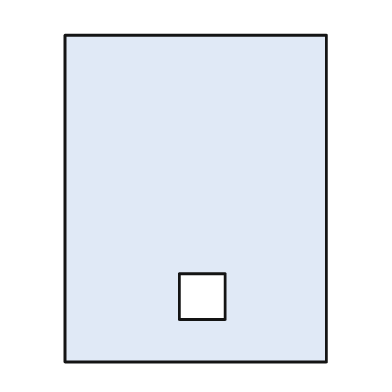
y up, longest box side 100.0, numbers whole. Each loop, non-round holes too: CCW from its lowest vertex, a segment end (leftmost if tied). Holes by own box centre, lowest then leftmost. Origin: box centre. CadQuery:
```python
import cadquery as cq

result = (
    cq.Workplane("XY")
    .moveTo(-40.0, -50.0)
    .lineTo(40.0, -50.0)
    .lineTo(40.0, 50.0)
    .lineTo(-40.0, 50.0)
    .close()
    .moveTo(-5.0, -37.0)
    .lineTo(9.0, -37.0)
    .lineTo(9.0, -23.0)
    .lineTo(-5.0, -23.0)
    .close()
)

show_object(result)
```